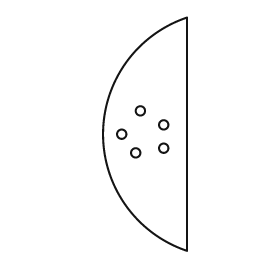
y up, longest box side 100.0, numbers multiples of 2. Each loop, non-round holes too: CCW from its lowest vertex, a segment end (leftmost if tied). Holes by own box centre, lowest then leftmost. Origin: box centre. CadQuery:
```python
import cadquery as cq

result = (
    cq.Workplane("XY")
    .moveTo(18.0, -50.0)
    .lineTo(18.0, 50.0)
    .threePointArc((-18.0, 0.0), (18.0, -50.0))
    .close()
    .moveTo(-4.0, -8.0)
    .circle(2.0)
    .moveTo(8.0, -6.0)
    .circle(2.0)
    .moveTo(-10.0, 0.0)
    .circle(2.0)
    .moveTo(8.0, 4.0)
    .circle(2.0)
    .moveTo(-2.0, 10.0)
    .circle(2.0)
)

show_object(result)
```